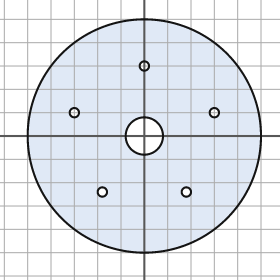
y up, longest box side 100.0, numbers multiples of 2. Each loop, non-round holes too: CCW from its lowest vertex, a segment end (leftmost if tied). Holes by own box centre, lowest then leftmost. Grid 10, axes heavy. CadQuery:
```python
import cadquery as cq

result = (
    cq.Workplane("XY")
    .moveTo(0.0, 0.0)
    .circle(50.0)
    .moveTo(-18.0, -24.0)
    .circle(2.0)
    .moveTo(18.0, -24.0)
    .circle(2.0)
    .moveTo(0.0, 0.0)
    .circle(8.0)
    .moveTo(-30.0, 10.0)
    .circle(2.0)
    .moveTo(30.0, 10.0)
    .circle(2.0)
    .moveTo(0.0, 30.0)
    .circle(2.0)
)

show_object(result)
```